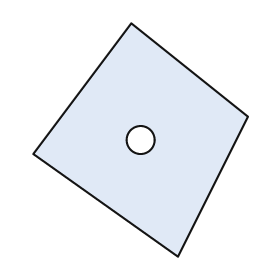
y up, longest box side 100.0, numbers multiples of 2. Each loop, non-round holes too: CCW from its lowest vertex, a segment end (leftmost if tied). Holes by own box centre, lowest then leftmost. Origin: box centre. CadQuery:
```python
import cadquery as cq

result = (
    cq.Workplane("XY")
    .moveTo(16.0, -50.0)
    .lineTo(46.0, 10.0)
    .lineTo(-4.0, 50.0)
    .lineTo(-46.0, -6.0)
    .close()
    .moveTo(0.0, 0.0)
    .circle(6.0)
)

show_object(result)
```